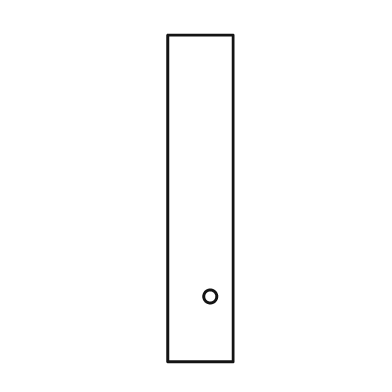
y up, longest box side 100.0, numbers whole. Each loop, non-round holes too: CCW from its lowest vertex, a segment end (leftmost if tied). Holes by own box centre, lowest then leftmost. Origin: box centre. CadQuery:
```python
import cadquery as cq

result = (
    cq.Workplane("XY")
    .moveTo(-10.0, -50.0)
    .lineTo(10.0, -50.0)
    .lineTo(10.0, 50.0)
    .lineTo(-10.0, 50.0)
    .close()
    .moveTo(3.0, -30.0)
    .circle(2.0)
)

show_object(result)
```